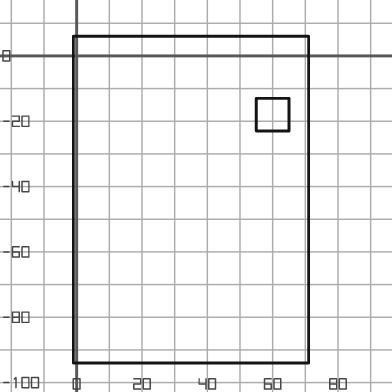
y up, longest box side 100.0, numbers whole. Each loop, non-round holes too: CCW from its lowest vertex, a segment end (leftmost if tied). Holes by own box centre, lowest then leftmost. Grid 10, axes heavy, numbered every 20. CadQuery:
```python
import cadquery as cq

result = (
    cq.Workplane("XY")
    .moveTo(-1.0, -94.0)
    .lineTo(71.0, -94.0)
    .lineTo(71.0, 6.0)
    .lineTo(-1.0, 6.0)
    .close()
    .moveTo(55.0, -23.0)
    .lineTo(65.0, -23.0)
    .lineTo(65.0, -13.0)
    .lineTo(55.0, -13.0)
    .close()
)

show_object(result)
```